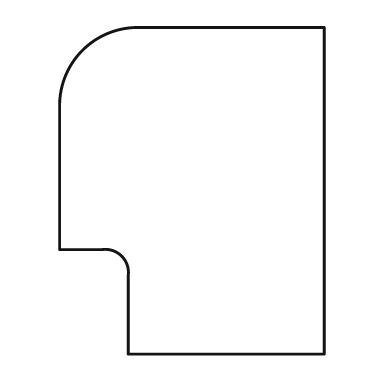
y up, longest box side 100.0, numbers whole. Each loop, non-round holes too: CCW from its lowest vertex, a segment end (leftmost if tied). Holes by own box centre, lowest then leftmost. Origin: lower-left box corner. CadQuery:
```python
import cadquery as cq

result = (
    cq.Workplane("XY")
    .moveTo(21.0, 0.0)
    .lineTo(81.0, 0.0)
    .lineTo(81.0, 100.0)
    .lineTo(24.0, 100.0)
    .threePointArc((7.0, 93.0), (0.0, 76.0))
    .lineTo(0.0, 32.0)
    .lineTo(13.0, 32.0)
    .threePointArc((19.0, 30.0), (21.0, 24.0))
    .close()
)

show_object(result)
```